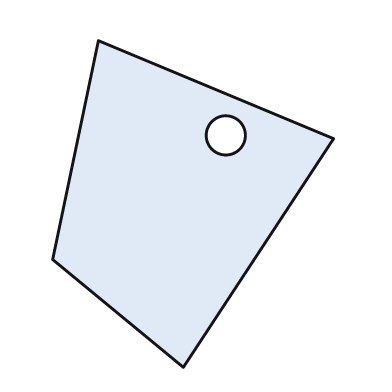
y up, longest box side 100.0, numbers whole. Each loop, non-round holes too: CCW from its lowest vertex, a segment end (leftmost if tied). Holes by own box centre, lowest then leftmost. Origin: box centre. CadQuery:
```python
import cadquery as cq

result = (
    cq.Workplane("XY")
    .moveTo(-3.0, -50.0)
    .lineTo(43.0, 20.0)
    .lineTo(-29.0, 50.0)
    .lineTo(-43.0, -17.0)
    .close()
    .moveTo(10.0, 21.0)
    .circle(6.0)
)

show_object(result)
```